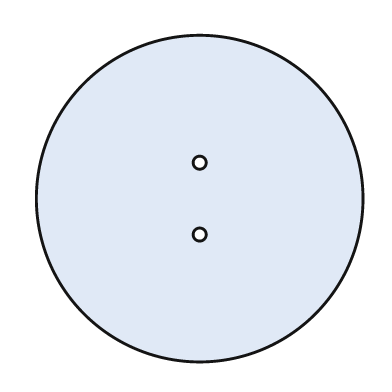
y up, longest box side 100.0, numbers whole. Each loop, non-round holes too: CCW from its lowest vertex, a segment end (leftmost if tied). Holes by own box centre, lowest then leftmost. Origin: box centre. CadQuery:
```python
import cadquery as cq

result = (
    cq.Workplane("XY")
    .moveTo(0.0, 0.0)
    .circle(50.0)
    .moveTo(0.0, -11.0)
    .circle(2.0)
    .moveTo(0.0, 11.0)
    .circle(2.0)
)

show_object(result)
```